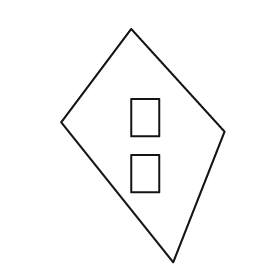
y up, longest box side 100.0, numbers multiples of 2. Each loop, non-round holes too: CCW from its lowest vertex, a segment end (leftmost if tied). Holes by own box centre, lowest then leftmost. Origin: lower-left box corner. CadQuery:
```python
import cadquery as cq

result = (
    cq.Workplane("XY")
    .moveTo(48.0, 0.0)
    .lineTo(70.0, 56.0)
    .lineTo(30.0, 100.0)
    .lineTo(0.0, 60.0)
    .close()
    .moveTo(30.0, 30.0)
    .lineTo(42.0, 30.0)
    .lineTo(42.0, 46.0)
    .lineTo(30.0, 46.0)
    .close()
    .moveTo(30.0, 54.0)
    .lineTo(42.0, 54.0)
    .lineTo(42.0, 70.0)
    .lineTo(30.0, 70.0)
    .close()
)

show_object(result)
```